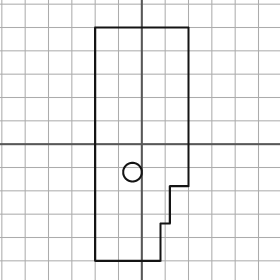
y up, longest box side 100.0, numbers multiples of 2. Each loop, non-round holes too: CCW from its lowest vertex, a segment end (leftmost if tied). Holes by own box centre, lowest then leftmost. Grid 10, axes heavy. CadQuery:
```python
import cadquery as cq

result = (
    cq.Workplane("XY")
    .moveTo(-20.0, -50.0)
    .lineTo(8.0, -50.0)
    .lineTo(8.0, -34.0)
    .lineTo(12.0, -34.0)
    .lineTo(12.0, -18.0)
    .lineTo(20.0, -18.0)
    .lineTo(20.0, 50.0)
    .lineTo(-20.0, 50.0)
    .close()
    .moveTo(-4.0, -12.0)
    .circle(4.0)
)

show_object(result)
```